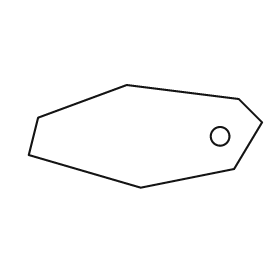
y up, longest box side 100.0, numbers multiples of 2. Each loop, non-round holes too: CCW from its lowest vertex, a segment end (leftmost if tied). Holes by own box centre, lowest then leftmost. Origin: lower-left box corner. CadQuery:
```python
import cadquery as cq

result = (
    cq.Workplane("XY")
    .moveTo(48.0, 0.0)
    .lineTo(88.0, 8.0)
    .lineTo(100.0, 28.0)
    .lineTo(90.0, 38.0)
    .lineTo(42.0, 44.0)
    .lineTo(4.0, 30.0)
    .lineTo(0.0, 14.0)
    .close()
    .moveTo(82.0, 22.0)
    .circle(4.0)
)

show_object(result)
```